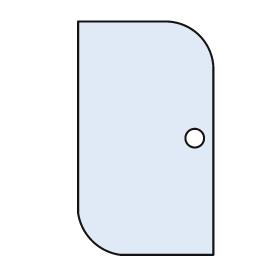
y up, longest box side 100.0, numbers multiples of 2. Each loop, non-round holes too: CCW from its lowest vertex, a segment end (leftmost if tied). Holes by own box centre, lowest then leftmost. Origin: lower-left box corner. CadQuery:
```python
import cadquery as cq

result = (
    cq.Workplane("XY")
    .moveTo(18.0, 0.0)
    .lineTo(58.0, 0.0)
    .lineTo(58.0, 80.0)
    .threePointArc((52.0, 94.0), (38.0, 100.0))
    .lineTo(0.0, 100.0)
    .lineTo(0.0, 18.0)
    .threePointArc((6.0, 6.0), (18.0, 0.0))
    .close()
    .moveTo(50.0, 50.0)
    .circle(4.0)
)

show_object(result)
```